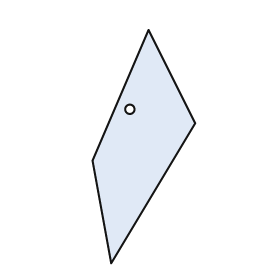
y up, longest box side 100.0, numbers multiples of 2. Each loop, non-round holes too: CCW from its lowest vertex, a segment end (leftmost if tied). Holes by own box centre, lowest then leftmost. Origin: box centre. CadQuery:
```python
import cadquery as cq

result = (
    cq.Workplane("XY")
    .moveTo(-14.0, -50.0)
    .lineTo(22.0, 10.0)
    .lineTo(2.0, 50.0)
    .lineTo(-22.0, -6.0)
    .close()
    .moveTo(-6.0, 16.0)
    .circle(2.0)
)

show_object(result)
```